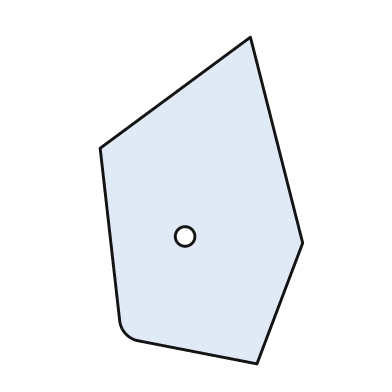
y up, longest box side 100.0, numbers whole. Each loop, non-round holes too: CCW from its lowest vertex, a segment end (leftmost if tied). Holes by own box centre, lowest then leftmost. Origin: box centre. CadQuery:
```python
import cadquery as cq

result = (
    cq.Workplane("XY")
    .moveTo(17.0, -50.0)
    .lineTo(31.0, -13.0)
    .lineTo(15.0, 50.0)
    .lineTo(-31.0, 16.0)
    .lineTo(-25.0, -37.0)
    .threePointArc((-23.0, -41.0), (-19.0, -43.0))
    .close()
    .moveTo(-5.0, -11.0)
    .circle(3.0)
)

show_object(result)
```